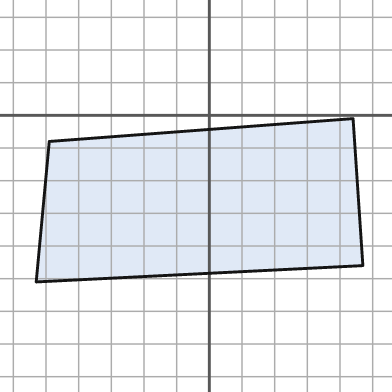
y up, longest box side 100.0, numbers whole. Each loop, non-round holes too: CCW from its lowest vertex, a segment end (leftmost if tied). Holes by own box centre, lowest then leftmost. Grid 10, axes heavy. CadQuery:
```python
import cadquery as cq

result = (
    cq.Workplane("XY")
    .moveTo(-53.0, -51.0)
    .lineTo(47.0, -46.0)
    .lineTo(44.0, -1.0)
    .lineTo(-49.0, -8.0)
    .close()
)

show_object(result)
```